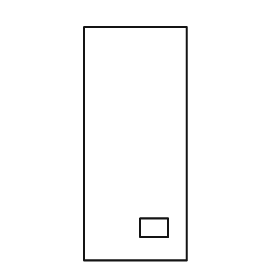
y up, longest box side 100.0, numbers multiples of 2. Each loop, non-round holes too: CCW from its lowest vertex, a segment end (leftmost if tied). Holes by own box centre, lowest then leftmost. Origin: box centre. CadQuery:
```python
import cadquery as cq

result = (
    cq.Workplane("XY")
    .moveTo(-22.0, -50.0)
    .lineTo(22.0, -50.0)
    .lineTo(22.0, 50.0)
    .lineTo(-22.0, 50.0)
    .close()
    .moveTo(2.0, -40.0)
    .lineTo(14.0, -40.0)
    .lineTo(14.0, -32.0)
    .lineTo(2.0, -32.0)
    .close()
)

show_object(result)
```